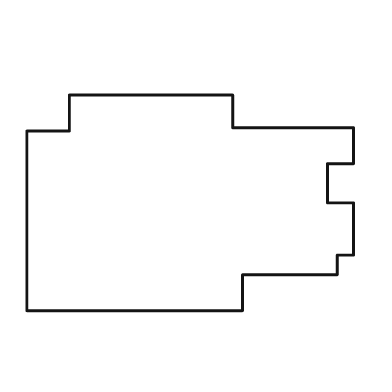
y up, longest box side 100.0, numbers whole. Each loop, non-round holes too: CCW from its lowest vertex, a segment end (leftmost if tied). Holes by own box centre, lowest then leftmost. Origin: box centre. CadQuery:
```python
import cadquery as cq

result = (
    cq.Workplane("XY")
    .moveTo(-50.0, -33.0)
    .lineTo(16.0, -33.0)
    .lineTo(16.0, -22.0)
    .lineTo(45.0, -22.0)
    .lineTo(45.0, -16.0)
    .lineTo(50.0, -16.0)
    .lineTo(50.0, 0.0)
    .lineTo(42.0, 0.0)
    .lineTo(42.0, 12.0)
    .lineTo(50.0, 12.0)
    .lineTo(50.0, 23.0)
    .lineTo(13.0, 23.0)
    .lineTo(13.0, 33.0)
    .lineTo(-37.0, 33.0)
    .lineTo(-37.0, 22.0)
    .lineTo(-50.0, 22.0)
    .close()
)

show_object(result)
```